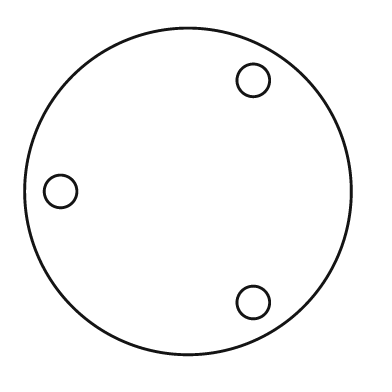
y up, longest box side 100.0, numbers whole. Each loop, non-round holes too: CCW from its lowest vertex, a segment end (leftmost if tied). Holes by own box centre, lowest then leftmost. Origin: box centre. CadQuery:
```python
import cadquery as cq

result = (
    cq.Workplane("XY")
    .moveTo(0.0, 0.0)
    .circle(50.0)
    .moveTo(20.0, -34.0)
    .circle(5.0)
    .moveTo(-39.0, 0.0)
    .circle(5.0)
    .moveTo(20.0, 34.0)
    .circle(5.0)
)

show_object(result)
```